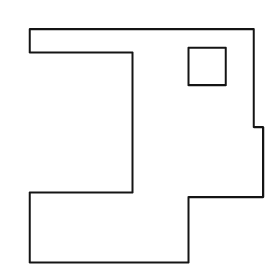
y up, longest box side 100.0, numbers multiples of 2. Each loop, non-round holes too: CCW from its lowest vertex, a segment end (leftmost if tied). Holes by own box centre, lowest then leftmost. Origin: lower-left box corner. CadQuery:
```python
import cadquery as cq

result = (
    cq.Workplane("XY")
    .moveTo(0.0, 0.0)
    .lineTo(68.0, 0.0)
    .lineTo(68.0, 28.0)
    .lineTo(100.0, 28.0)
    .lineTo(100.0, 58.0)
    .lineTo(96.0, 58.0)
    .lineTo(96.0, 100.0)
    .lineTo(0.0, 100.0)
    .lineTo(0.0, 90.0)
    .lineTo(44.0, 90.0)
    .lineTo(44.0, 30.0)
    .lineTo(0.0, 30.0)
    .close()
    .moveTo(68.0, 76.0)
    .lineTo(84.0, 76.0)
    .lineTo(84.0, 92.0)
    .lineTo(68.0, 92.0)
    .close()
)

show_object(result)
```